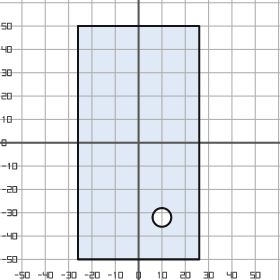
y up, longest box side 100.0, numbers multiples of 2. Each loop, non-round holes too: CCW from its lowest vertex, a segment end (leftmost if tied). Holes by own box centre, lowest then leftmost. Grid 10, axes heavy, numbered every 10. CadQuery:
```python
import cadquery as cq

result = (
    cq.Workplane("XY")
    .moveTo(-26.0, -50.0)
    .lineTo(26.0, -50.0)
    .lineTo(26.0, 50.0)
    .lineTo(-26.0, 50.0)
    .close()
    .moveTo(10.0, -32.0)
    .circle(4.0)
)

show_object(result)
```